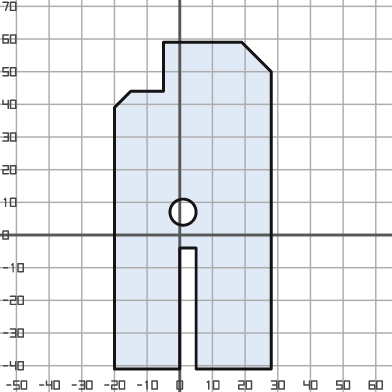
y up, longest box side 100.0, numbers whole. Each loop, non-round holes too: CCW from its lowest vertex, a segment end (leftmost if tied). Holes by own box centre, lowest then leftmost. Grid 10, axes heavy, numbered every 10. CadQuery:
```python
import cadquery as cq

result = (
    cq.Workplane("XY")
    .moveTo(-20.0, -41.0)
    .lineTo(0.0, -41.0)
    .lineTo(0.0, -4.0)
    .lineTo(5.0, -4.0)
    .lineTo(5.0, -41.0)
    .lineTo(28.0, -41.0)
    .lineTo(28.0, 50.0)
    .lineTo(19.0, 59.0)
    .lineTo(-5.0, 59.0)
    .lineTo(-5.0, 44.0)
    .lineTo(-15.0, 44.0)
    .lineTo(-20.0, 39.0)
    .close()
    .moveTo(1.0, 7.0)
    .circle(4.0)
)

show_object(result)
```